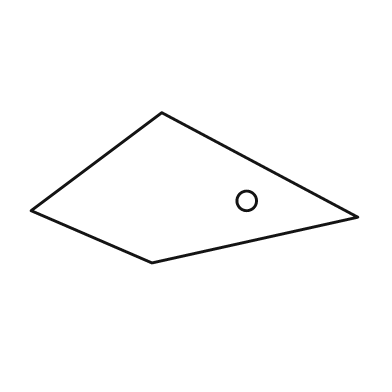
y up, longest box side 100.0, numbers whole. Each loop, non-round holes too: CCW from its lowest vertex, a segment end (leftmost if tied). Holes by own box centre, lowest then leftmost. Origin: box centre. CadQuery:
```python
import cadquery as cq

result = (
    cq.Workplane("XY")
    .moveTo(-13.0, -23.0)
    .lineTo(50.0, -9.0)
    .lineTo(-10.0, 23.0)
    .lineTo(-50.0, -7.0)
    .close()
    .moveTo(16.0, -4.0)
    .circle(3.0)
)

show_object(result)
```